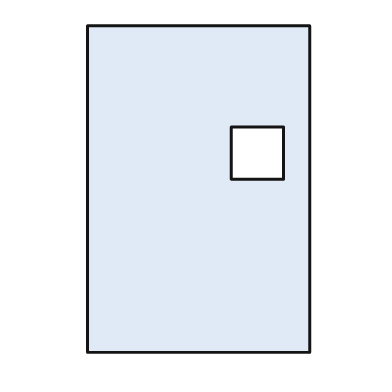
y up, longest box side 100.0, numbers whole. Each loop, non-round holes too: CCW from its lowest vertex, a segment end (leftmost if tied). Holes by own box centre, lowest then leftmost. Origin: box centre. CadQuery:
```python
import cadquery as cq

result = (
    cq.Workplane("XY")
    .moveTo(-34.0, -50.0)
    .lineTo(34.0, -50.0)
    .lineTo(34.0, 50.0)
    .lineTo(-34.0, 50.0)
    .close()
    .moveTo(10.0, 3.0)
    .lineTo(26.0, 3.0)
    .lineTo(26.0, 19.0)
    .lineTo(10.0, 19.0)
    .close()
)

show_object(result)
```